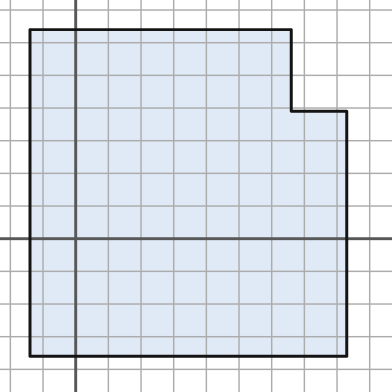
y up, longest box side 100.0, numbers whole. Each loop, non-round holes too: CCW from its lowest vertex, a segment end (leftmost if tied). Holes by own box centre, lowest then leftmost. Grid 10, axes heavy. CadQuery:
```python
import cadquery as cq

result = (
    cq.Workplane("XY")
    .moveTo(-14.0, -36.0)
    .lineTo(83.0, -36.0)
    .lineTo(83.0, 39.0)
    .lineTo(66.0, 39.0)
    .lineTo(66.0, 64.0)
    .lineTo(-14.0, 64.0)
    .close()
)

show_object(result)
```